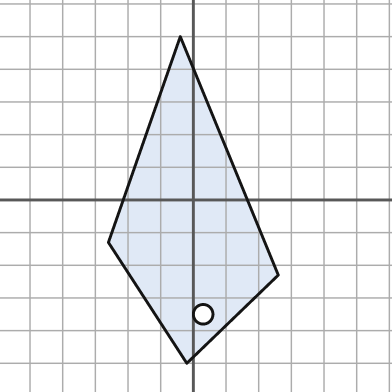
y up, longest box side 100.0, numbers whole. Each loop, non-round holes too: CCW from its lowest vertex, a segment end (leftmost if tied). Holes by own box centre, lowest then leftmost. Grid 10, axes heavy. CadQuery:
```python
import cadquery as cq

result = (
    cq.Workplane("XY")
    .moveTo(-2.0, -50.0)
    .lineTo(26.0, -23.0)
    .lineTo(-4.0, 50.0)
    .lineTo(-26.0, -13.0)
    .close()
    .moveTo(3.0, -35.0)
    .circle(3.0)
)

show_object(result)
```